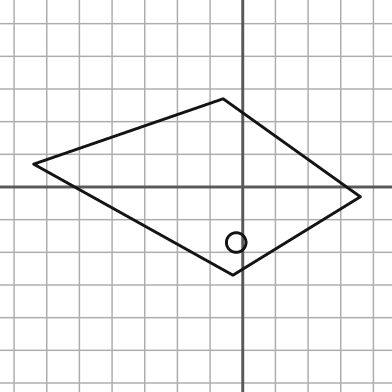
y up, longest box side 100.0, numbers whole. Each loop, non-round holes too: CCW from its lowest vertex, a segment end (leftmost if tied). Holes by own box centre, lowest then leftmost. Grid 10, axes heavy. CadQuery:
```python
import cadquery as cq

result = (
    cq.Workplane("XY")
    .moveTo(-3.0, -27.0)
    .lineTo(36.0, -3.0)
    .lineTo(-6.0, 27.0)
    .lineTo(-64.0, 7.0)
    .close()
    .moveTo(-2.0, -17.0)
    .circle(3.0)
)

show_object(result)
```